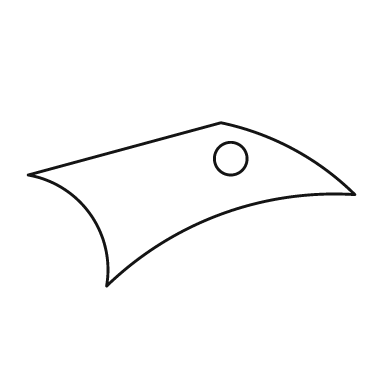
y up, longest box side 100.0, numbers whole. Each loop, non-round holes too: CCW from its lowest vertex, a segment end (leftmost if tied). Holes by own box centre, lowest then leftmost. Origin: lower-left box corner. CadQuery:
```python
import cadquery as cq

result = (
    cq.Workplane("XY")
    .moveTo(24.0, 0.0)
    .threePointArc((59.0, 22.0), (100.0, 28.0))
    .threePointArc((81.0, 42.0), (59.0, 50.0))
    .lineTo(0.0, 34.0)
    .threePointArc((19.0, 22.0), (24.0, 0.0))
    .close()
    .moveTo(62.0, 39.0)
    .circle(5.0)
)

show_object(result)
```